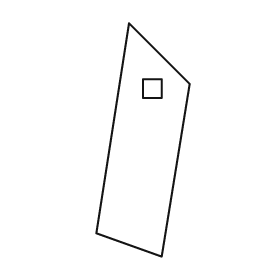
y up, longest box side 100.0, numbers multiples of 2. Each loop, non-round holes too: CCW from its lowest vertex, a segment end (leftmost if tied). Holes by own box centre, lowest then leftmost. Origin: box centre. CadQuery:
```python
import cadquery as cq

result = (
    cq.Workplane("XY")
    .moveTo(8.0, -50.0)
    .lineTo(20.0, 24.0)
    .lineTo(-6.0, 50.0)
    .lineTo(-20.0, -40.0)
    .close()
    .moveTo(0.0, 18.0)
    .lineTo(8.0, 18.0)
    .lineTo(8.0, 26.0)
    .lineTo(0.0, 26.0)
    .close()
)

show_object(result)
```